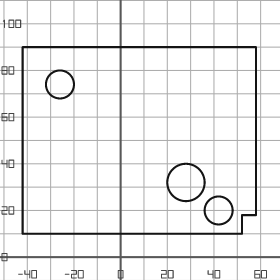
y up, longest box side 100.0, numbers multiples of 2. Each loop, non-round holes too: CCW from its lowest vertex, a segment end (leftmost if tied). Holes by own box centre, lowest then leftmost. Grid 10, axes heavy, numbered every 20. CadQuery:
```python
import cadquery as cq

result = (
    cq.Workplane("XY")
    .moveTo(-42.0, 10.0)
    .lineTo(52.0, 10.0)
    .lineTo(52.0, 18.0)
    .lineTo(58.0, 18.0)
    .lineTo(58.0, 90.0)
    .lineTo(-42.0, 90.0)
    .close()
    .moveTo(42.0, 20.0)
    .circle(6.0)
    .moveTo(28.0, 32.0)
    .circle(8.0)
    .moveTo(-26.0, 74.0)
    .circle(6.0)
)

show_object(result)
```